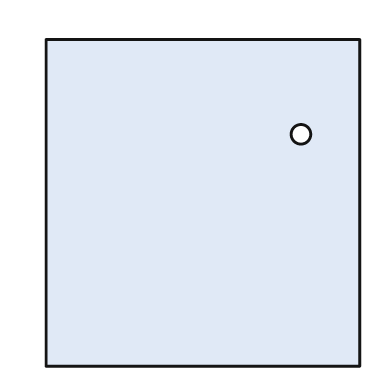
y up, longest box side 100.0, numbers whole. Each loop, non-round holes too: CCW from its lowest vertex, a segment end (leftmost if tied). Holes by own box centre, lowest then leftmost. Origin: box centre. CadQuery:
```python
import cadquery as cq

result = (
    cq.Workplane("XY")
    .moveTo(-48.0, -50.0)
    .lineTo(48.0, -50.0)
    .lineTo(48.0, 50.0)
    .lineTo(-48.0, 50.0)
    .close()
    .moveTo(30.0, 21.0)
    .circle(3.0)
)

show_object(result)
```